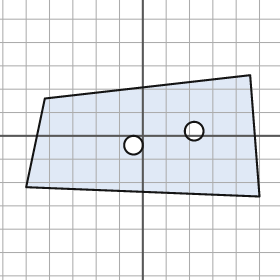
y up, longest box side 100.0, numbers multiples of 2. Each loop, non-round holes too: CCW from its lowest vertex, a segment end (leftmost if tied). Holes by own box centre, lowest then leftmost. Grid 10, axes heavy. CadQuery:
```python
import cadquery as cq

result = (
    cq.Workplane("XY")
    .moveTo(50.0, -26.0)
    .lineTo(46.0, 26.0)
    .lineTo(-42.0, 16.0)
    .lineTo(-50.0, -22.0)
    .close()
    .moveTo(-4.0, -4.0)
    .circle(4.0)
    .moveTo(22.0, 2.0)
    .circle(4.0)
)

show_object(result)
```